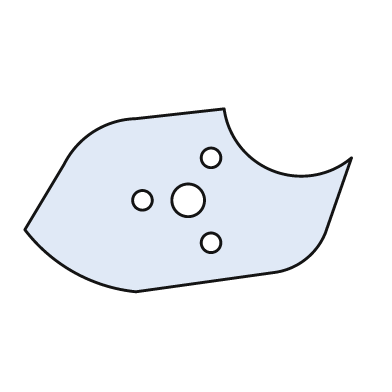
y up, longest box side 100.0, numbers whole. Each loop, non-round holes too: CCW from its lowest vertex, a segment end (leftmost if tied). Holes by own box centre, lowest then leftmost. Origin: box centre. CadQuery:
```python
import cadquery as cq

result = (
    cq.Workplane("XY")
    .moveTo(-16.0, -28.0)
    .lineTo(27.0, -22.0)
    .threePointArc((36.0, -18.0), (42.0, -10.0))
    .lineTo(50.0, 13.0)
    .threePointArc((26.0, 9.0), (11.0, 28.0))
    .lineTo(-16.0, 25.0)
    .threePointArc((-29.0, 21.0), (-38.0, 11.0))
    .lineTo(-50.0, -9.0)
    .threePointArc((-35.0, -22.0), (-16.0, -28.0))
    .close()
    .moveTo(7.0, -13.0)
    .circle(3.0)
    .moveTo(-14.0, 0.0)
    .circle(3.0)
    .moveTo(0.0, 0.0)
    .circle(5.0)
    .moveTo(7.0, 13.0)
    .circle(3.0)
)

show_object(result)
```